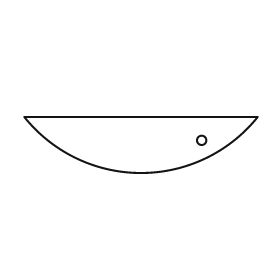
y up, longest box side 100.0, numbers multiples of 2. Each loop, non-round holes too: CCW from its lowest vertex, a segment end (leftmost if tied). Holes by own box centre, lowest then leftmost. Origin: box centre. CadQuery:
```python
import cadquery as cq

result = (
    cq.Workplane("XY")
    .moveTo(-50.0, 12.0)
    .threePointArc((0.0, -12.0), (50.0, 12.0))
    .close()
    .moveTo(26.0, 2.0)
    .circle(2.0)
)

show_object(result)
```